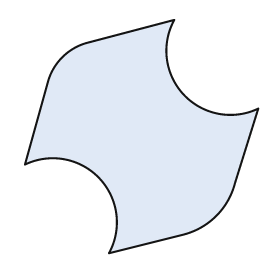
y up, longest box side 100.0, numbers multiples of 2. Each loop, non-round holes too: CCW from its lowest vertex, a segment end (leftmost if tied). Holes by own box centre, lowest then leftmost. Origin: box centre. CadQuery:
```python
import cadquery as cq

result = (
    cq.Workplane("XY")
    .moveTo(-14.0, -50.0)
    .lineTo(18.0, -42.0)
    .threePointArc((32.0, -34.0), (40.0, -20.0))
    .lineTo(50.0, 12.0)
    .threePointArc((18.0, 18.0), (14.0, 50.0))
    .lineTo(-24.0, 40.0)
    .threePointArc((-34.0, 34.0), (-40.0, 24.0))
    .lineTo(-50.0, -12.0)
    .threePointArc((-18.0, -18.0), (-14.0, -50.0))
    .close()
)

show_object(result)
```